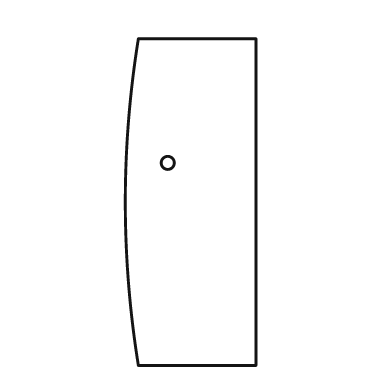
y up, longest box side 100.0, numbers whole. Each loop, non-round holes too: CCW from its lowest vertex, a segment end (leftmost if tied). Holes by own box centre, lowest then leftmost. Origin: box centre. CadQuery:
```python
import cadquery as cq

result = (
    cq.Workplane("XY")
    .moveTo(-16.0, -50.0)
    .lineTo(20.0, -50.0)
    .lineTo(20.0, 50.0)
    .lineTo(-16.0, 50.0)
    .threePointArc((-20.0, 0.0), (-16.0, -50.0))
    .close()
    .moveTo(-7.0, 12.0)
    .circle(2.0)
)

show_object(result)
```